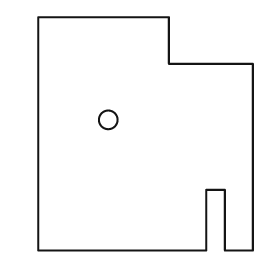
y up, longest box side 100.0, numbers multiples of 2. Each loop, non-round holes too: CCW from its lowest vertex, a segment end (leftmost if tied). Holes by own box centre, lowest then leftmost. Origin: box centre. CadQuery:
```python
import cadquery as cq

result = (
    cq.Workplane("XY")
    .moveTo(-46.0, -50.0)
    .lineTo(26.0, -50.0)
    .lineTo(26.0, -24.0)
    .lineTo(34.0, -24.0)
    .lineTo(34.0, -50.0)
    .lineTo(46.0, -50.0)
    .lineTo(46.0, 30.0)
    .lineTo(10.0, 30.0)
    .lineTo(10.0, 50.0)
    .lineTo(-46.0, 50.0)
    .close()
    .moveTo(-16.0, 6.0)
    .circle(4.0)
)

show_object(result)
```